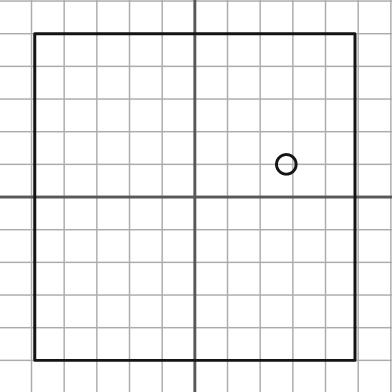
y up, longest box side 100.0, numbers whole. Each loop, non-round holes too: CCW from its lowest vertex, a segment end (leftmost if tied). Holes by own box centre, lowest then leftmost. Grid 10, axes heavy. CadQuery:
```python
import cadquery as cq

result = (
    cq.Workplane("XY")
    .moveTo(-49.0, -50.0)
    .lineTo(49.0, -50.0)
    .lineTo(49.0, 50.0)
    .lineTo(-49.0, 50.0)
    .close()
    .moveTo(28.0, 10.0)
    .circle(3.0)
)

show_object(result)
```